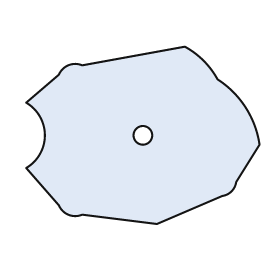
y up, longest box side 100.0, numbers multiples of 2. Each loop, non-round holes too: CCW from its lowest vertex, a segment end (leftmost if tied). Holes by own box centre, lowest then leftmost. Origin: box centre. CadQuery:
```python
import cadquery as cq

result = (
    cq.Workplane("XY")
    .moveTo(6.0, -38.0)
    .lineTo(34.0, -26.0)
    .threePointArc((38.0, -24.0), (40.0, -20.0))
    .lineTo(50.0, -4.0)
    .threePointArc((44.0, 12.0), (32.0, 24.0))
    .threePointArc((26.0, 32.0), (18.0, 38.0))
    .lineTo(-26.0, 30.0)
    .threePointArc((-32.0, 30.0), (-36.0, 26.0))
    .lineTo(-50.0, 14.0)
    .threePointArc((-42.0, 0.0), (-50.0, -14.0))
    .lineTo(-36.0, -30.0)
    .threePointArc((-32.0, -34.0), (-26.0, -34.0))
    .close()
    .moveTo(0.0, 0.0)
    .circle(4.0)
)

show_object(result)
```